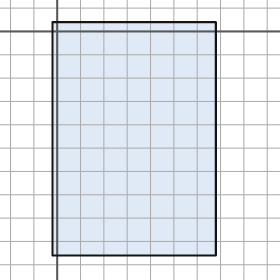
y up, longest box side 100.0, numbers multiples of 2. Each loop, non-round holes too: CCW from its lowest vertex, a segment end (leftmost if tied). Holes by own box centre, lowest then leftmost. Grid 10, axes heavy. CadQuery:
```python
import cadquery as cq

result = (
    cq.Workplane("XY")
    .moveTo(-2.0, -96.0)
    .lineTo(68.0, -96.0)
    .lineTo(68.0, 4.0)
    .lineTo(-2.0, 4.0)
    .close()
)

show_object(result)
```